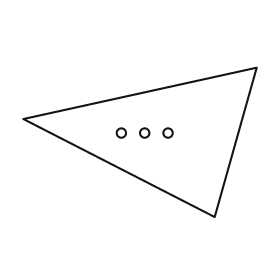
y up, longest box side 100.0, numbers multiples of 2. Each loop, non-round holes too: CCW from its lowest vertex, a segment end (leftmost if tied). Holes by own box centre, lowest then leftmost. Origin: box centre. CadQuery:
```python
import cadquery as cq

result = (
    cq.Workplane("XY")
    .moveTo(32.0, -32.0)
    .lineTo(50.0, 32.0)
    .lineTo(-50.0, 10.0)
    .close()
    .moveTo(-8.0, 4.0)
    .circle(2.0)
    .moveTo(2.0, 4.0)
    .circle(2.0)
    .moveTo(12.0, 4.0)
    .circle(2.0)
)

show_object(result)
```